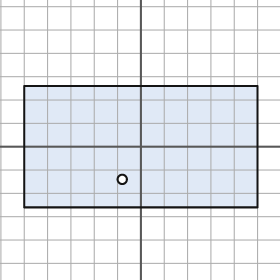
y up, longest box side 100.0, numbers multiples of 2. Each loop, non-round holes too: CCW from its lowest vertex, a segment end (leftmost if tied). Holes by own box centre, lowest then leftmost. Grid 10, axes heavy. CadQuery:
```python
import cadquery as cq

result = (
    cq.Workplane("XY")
    .moveTo(-50.0, -26.0)
    .lineTo(50.0, -26.0)
    .lineTo(50.0, 26.0)
    .lineTo(-50.0, 26.0)
    .close()
    .moveTo(-8.0, -14.0)
    .circle(2.0)
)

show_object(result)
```